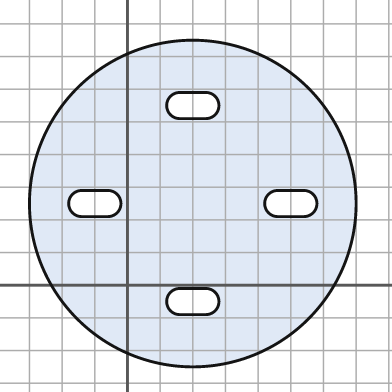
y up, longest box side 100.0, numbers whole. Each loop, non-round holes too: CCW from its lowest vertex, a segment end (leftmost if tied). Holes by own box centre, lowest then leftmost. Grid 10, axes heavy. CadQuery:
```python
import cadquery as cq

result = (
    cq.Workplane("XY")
    .moveTo(20.0, 25.0)
    .circle(50.0)
    .moveTo(16.0, -9.0)
    .lineTo(24.0, -9.0)
    .threePointArc((28.0, -5.0), (24.0, -1.0))
    .lineTo(16.0, -1.0)
    .threePointArc((12.0, -5.0), (16.0, -9.0))
    .close()
    .moveTo(-14.0, 21.0)
    .lineTo(-6.0, 21.0)
    .threePointArc((-2.0, 25.0), (-6.0, 29.0))
    .lineTo(-14.0, 29.0)
    .threePointArc((-18.0, 25.0), (-14.0, 21.0))
    .close()
    .moveTo(46.0, 21.0)
    .lineTo(54.0, 21.0)
    .threePointArc((58.0, 25.0), (54.0, 29.0))
    .lineTo(46.0, 29.0)
    .threePointArc((42.0, 25.0), (46.0, 21.0))
    .close()
    .moveTo(16.0, 51.0)
    .lineTo(24.0, 51.0)
    .threePointArc((28.0, 55.0), (24.0, 59.0))
    .lineTo(16.0, 59.0)
    .threePointArc((12.0, 55.0), (16.0, 51.0))
    .close()
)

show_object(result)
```